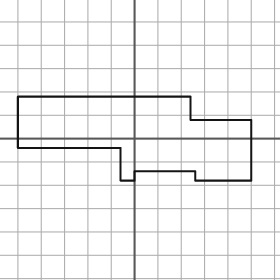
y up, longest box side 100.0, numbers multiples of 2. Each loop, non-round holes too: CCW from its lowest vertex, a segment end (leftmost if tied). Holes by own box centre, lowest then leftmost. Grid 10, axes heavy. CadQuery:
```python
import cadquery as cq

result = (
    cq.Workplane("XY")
    .moveTo(-6.0, -18.0)
    .lineTo(0.0, -18.0)
    .lineTo(0.0, -14.0)
    .lineTo(26.0, -14.0)
    .lineTo(26.0, -18.0)
    .lineTo(50.0, -18.0)
    .lineTo(50.0, 8.0)
    .lineTo(24.0, 8.0)
    .lineTo(24.0, 18.0)
    .lineTo(-50.0, 18.0)
    .lineTo(-50.0, -4.0)
    .lineTo(-6.0, -4.0)
    .close()
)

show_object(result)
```